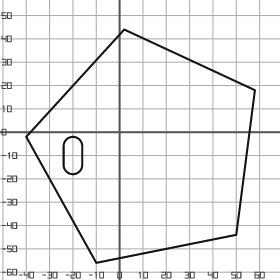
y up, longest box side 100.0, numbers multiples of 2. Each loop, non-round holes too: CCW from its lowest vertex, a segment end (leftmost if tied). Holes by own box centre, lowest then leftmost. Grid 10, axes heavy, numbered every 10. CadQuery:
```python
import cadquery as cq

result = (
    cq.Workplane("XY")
    .moveTo(-10.0, -56.0)
    .lineTo(50.0, -44.0)
    .lineTo(58.0, 18.0)
    .lineTo(2.0, 44.0)
    .lineTo(-40.0, -2.0)
    .close()
    .moveTo(-24.0, -14.0)
    .threePointArc((-20.0, -18.0), (-16.0, -14.0))
    .lineTo(-16.0, -6.0)
    .threePointArc((-20.0, -2.0), (-24.0, -6.0))
    .close()
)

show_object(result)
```